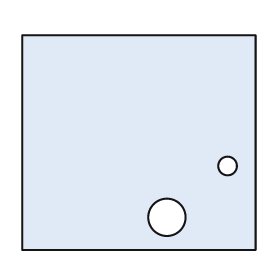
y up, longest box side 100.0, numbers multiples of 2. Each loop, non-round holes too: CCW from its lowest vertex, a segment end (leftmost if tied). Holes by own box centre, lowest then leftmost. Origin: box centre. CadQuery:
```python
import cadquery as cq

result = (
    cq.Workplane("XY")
    .moveTo(-50.0, -46.0)
    .lineTo(50.0, -46.0)
    .lineTo(50.0, 46.0)
    .lineTo(-50.0, 46.0)
    .close()
    .moveTo(12.0, -32.0)
    .circle(8.0)
    .moveTo(38.0, -10.0)
    .circle(4.0)
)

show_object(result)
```